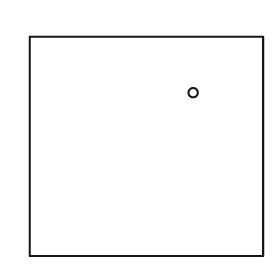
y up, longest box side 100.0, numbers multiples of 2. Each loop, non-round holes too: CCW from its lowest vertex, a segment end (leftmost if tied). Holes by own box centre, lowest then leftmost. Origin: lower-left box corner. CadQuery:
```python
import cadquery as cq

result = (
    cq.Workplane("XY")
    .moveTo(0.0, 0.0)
    .lineTo(100.0, 0.0)
    .lineTo(100.0, 94.0)
    .lineTo(0.0, 94.0)
    .close()
    .moveTo(70.0, 70.0)
    .circle(2.0)
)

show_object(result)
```